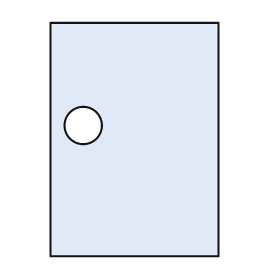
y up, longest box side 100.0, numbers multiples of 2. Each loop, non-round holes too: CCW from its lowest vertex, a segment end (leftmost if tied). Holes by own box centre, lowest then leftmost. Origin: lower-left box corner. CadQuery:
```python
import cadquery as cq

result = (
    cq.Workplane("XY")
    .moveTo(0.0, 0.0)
    .lineTo(72.0, 0.0)
    .lineTo(72.0, 100.0)
    .lineTo(0.0, 100.0)
    .close()
    .moveTo(14.0, 56.0)
    .circle(8.0)
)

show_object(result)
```